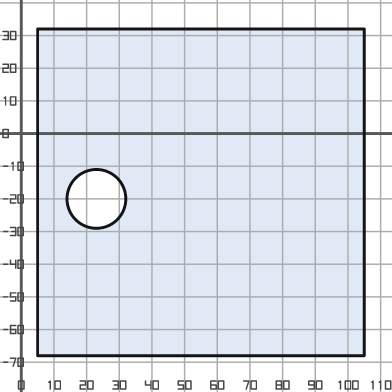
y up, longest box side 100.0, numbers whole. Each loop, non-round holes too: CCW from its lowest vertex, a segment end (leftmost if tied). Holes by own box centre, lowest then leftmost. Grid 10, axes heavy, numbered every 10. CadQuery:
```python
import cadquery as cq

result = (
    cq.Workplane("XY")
    .moveTo(5.0, -68.0)
    .lineTo(105.0, -68.0)
    .lineTo(105.0, 32.0)
    .lineTo(5.0, 32.0)
    .close()
    .moveTo(23.0, -20.0)
    .circle(9.0)
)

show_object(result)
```